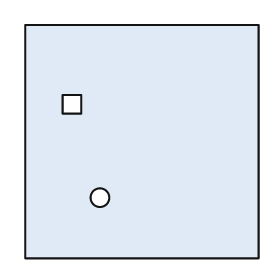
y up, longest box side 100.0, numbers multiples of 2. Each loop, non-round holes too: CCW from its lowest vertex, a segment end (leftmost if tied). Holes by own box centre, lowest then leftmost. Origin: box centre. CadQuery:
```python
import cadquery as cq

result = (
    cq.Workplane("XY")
    .moveTo(-50.0, -50.0)
    .lineTo(50.0, -50.0)
    .lineTo(50.0, 50.0)
    .lineTo(-50.0, 50.0)
    .close()
    .moveTo(-18.0, -24.0)
    .circle(4.0)
    .moveTo(-34.0, 12.0)
    .lineTo(-26.0, 12.0)
    .lineTo(-26.0, 20.0)
    .lineTo(-34.0, 20.0)
    .close()
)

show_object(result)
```